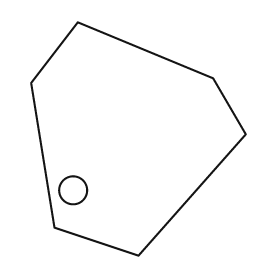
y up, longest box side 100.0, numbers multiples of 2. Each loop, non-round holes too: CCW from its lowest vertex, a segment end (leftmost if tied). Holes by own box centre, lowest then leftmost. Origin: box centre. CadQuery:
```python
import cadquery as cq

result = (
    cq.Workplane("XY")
    .moveTo(0.0, -50.0)
    .lineTo(46.0, 2.0)
    .lineTo(32.0, 26.0)
    .lineTo(-26.0, 50.0)
    .lineTo(-46.0, 24.0)
    .lineTo(-36.0, -38.0)
    .close()
    .moveTo(-28.0, -22.0)
    .circle(6.0)
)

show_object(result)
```